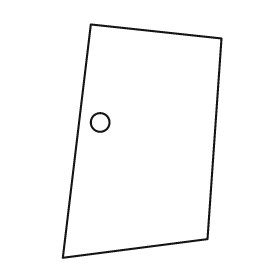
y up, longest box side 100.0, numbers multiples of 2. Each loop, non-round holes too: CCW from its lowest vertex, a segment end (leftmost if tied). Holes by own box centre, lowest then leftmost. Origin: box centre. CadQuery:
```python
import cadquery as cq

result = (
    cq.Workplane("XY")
    .moveTo(-34.0, -50.0)
    .lineTo(28.0, -42.0)
    .lineTo(34.0, 44.0)
    .lineTo(-22.0, 50.0)
    .close()
    .moveTo(-18.0, 8.0)
    .circle(4.0)
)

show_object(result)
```